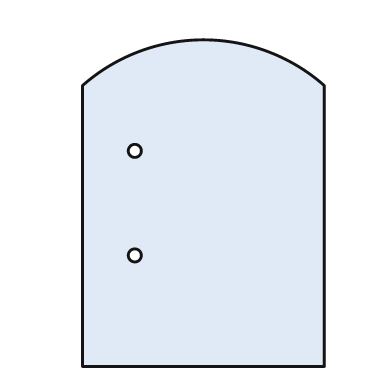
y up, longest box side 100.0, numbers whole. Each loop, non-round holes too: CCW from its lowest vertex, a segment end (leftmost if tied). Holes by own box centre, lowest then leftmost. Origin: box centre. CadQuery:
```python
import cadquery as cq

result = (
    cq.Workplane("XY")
    .moveTo(-37.0, -50.0)
    .lineTo(37.0, -50.0)
    .lineTo(37.0, 36.0)
    .threePointArc((0.0, 50.0), (-37.0, 36.0))
    .close()
    .moveTo(-21.0, -16.0)
    .circle(2.0)
    .moveTo(-21.0, 16.0)
    .circle(2.0)
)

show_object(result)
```